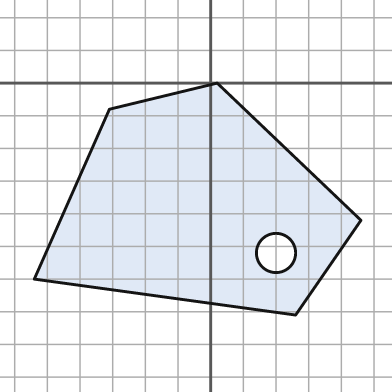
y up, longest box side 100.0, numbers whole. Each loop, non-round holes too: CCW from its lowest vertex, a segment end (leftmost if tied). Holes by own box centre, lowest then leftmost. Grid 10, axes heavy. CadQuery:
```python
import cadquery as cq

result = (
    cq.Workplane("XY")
    .moveTo(26.0, -71.0)
    .lineTo(46.0, -42.0)
    .lineTo(2.0, 0.0)
    .lineTo(-31.0, -8.0)
    .lineTo(-54.0, -60.0)
    .close()
    .moveTo(20.0, -52.0)
    .circle(6.0)
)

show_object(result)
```